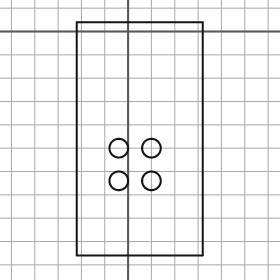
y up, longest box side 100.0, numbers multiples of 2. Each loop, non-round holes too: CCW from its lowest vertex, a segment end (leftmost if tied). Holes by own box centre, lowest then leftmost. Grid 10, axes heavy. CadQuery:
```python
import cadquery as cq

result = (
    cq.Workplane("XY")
    .moveTo(-22.0, -96.0)
    .lineTo(32.0, -96.0)
    .lineTo(32.0, 4.0)
    .lineTo(-22.0, 4.0)
    .close()
    .moveTo(-4.0, -64.0)
    .circle(4.0)
    .moveTo(10.0, -64.0)
    .circle(4.0)
    .moveTo(-4.0, -50.0)
    .circle(4.0)
    .moveTo(10.0, -50.0)
    .circle(4.0)
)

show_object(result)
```